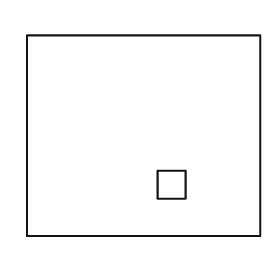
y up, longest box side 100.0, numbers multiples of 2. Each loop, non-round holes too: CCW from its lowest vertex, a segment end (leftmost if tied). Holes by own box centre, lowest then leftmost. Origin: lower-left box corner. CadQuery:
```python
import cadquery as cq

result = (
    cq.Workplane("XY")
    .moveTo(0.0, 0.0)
    .lineTo(100.0, 0.0)
    .lineTo(100.0, 86.0)
    .lineTo(0.0, 86.0)
    .close()
    .moveTo(56.0, 16.0)
    .lineTo(68.0, 16.0)
    .lineTo(68.0, 28.0)
    .lineTo(56.0, 28.0)
    .close()
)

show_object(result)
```